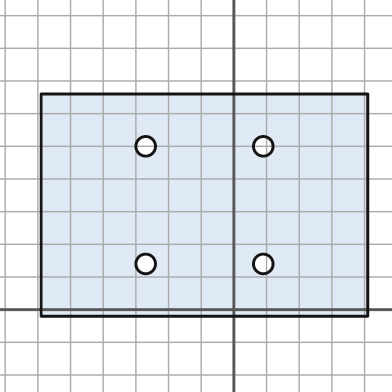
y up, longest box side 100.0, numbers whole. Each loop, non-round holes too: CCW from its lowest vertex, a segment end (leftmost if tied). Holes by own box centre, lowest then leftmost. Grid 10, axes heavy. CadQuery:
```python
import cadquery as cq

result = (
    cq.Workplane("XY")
    .moveTo(-59.0, -2.0)
    .lineTo(41.0, -2.0)
    .lineTo(41.0, 66.0)
    .lineTo(-59.0, 66.0)
    .close()
    .moveTo(-27.0, 14.0)
    .circle(3.0)
    .moveTo(9.0, 14.0)
    .circle(3.0)
    .moveTo(-27.0, 50.0)
    .circle(3.0)
    .moveTo(9.0, 50.0)
    .circle(3.0)
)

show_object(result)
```